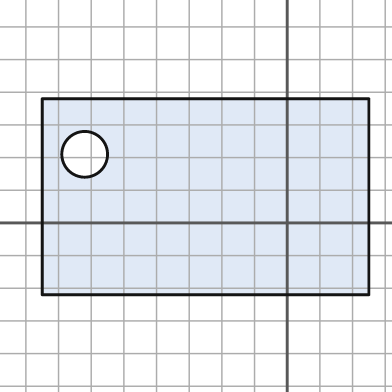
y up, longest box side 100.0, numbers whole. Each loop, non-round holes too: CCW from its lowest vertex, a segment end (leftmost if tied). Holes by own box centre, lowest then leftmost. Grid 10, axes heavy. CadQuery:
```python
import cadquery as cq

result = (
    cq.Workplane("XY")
    .moveTo(-75.0, -22.0)
    .lineTo(25.0, -22.0)
    .lineTo(25.0, 38.0)
    .lineTo(-75.0, 38.0)
    .close()
    .moveTo(-62.0, 21.0)
    .circle(7.0)
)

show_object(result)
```